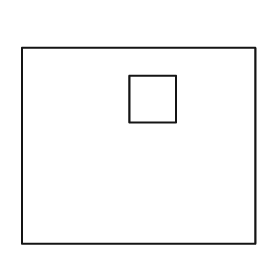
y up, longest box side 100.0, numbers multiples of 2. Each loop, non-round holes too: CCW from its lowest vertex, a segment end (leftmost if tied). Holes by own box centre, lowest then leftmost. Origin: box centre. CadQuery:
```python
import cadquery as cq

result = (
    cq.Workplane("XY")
    .moveTo(-50.0, -42.0)
    .lineTo(50.0, -42.0)
    .lineTo(50.0, 42.0)
    .lineTo(-50.0, 42.0)
    .close()
    .moveTo(-4.0, 10.0)
    .lineTo(16.0, 10.0)
    .lineTo(16.0, 30.0)
    .lineTo(-4.0, 30.0)
    .close()
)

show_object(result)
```